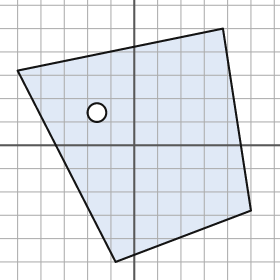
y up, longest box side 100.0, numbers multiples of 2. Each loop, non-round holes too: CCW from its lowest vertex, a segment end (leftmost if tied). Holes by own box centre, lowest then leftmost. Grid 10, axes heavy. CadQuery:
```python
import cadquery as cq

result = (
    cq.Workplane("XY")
    .moveTo(-8.0, -50.0)
    .lineTo(50.0, -28.0)
    .lineTo(38.0, 50.0)
    .lineTo(-50.0, 32.0)
    .close()
    .moveTo(-16.0, 14.0)
    .circle(4.0)
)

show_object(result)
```